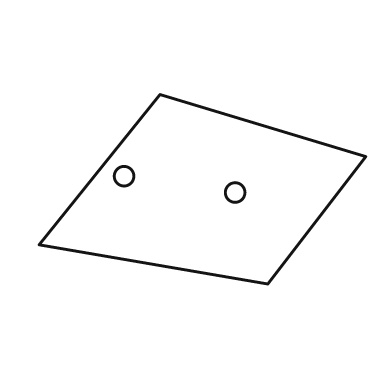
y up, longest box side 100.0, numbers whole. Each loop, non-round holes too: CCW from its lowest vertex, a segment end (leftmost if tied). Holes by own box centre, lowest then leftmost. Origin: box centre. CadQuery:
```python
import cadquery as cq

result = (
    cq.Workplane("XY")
    .moveTo(20.0, -29.0)
    .lineTo(50.0, 10.0)
    .lineTo(-13.0, 29.0)
    .lineTo(-50.0, -17.0)
    .close()
    .moveTo(10.0, -1.0)
    .circle(3.0)
    .moveTo(-24.0, 4.0)
    .circle(3.0)
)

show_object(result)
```